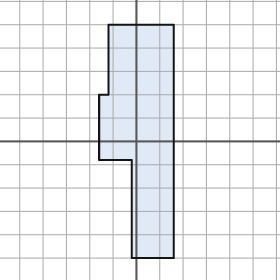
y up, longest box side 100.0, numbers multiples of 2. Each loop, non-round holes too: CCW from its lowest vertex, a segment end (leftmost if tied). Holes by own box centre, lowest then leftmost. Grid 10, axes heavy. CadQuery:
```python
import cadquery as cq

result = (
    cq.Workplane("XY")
    .moveTo(-2.0, -50.0)
    .lineTo(16.0, -50.0)
    .lineTo(16.0, 50.0)
    .lineTo(-12.0, 50.0)
    .lineTo(-12.0, 20.0)
    .lineTo(-16.0, 20.0)
    .lineTo(-16.0, -8.0)
    .lineTo(-2.0, -8.0)
    .close()
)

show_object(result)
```